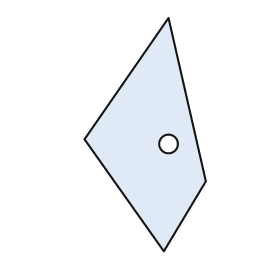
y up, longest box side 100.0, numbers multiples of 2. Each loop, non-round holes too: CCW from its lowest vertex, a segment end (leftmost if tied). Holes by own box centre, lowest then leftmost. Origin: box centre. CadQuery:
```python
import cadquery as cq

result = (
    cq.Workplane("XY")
    .moveTo(8.0, -50.0)
    .lineTo(26.0, -20.0)
    .lineTo(10.0, 50.0)
    .lineTo(-26.0, -2.0)
    .close()
    .moveTo(10.0, -4.0)
    .circle(4.0)
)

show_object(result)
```